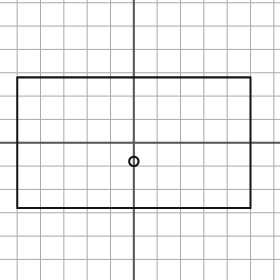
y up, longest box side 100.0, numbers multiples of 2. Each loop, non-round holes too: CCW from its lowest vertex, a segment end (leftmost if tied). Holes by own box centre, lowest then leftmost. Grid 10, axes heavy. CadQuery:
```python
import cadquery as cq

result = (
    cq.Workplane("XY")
    .moveTo(-50.0, -28.0)
    .lineTo(50.0, -28.0)
    .lineTo(50.0, 28.0)
    .lineTo(-50.0, 28.0)
    .close()
    .moveTo(0.0, -8.0)
    .circle(2.0)
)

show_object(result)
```